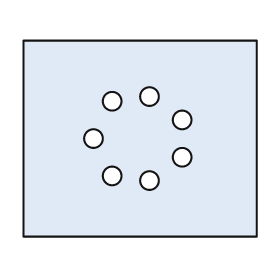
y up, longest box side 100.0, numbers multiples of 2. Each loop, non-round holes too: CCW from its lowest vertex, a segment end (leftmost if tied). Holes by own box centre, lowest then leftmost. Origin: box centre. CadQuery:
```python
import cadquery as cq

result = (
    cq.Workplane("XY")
    .moveTo(-50.0, -42.0)
    .lineTo(50.0, -42.0)
    .lineTo(50.0, 42.0)
    .lineTo(-50.0, 42.0)
    .close()
    .moveTo(4.0, -18.0)
    .circle(4.0)
    .moveTo(-12.0, -16.0)
    .circle(4.0)
    .moveTo(18.0, -8.0)
    .circle(4.0)
    .moveTo(-20.0, 0.0)
    .circle(4.0)
    .moveTo(18.0, 8.0)
    .circle(4.0)
    .moveTo(-12.0, 16.0)
    .circle(4.0)
    .moveTo(4.0, 18.0)
    .circle(4.0)
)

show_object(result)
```